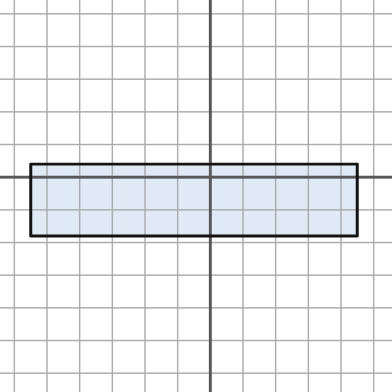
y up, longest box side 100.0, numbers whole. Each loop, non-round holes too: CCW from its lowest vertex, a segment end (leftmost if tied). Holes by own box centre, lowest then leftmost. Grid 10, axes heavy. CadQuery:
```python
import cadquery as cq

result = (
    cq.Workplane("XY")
    .moveTo(-55.0, -18.0)
    .lineTo(45.0, -18.0)
    .lineTo(45.0, 4.0)
    .lineTo(-55.0, 4.0)
    .close()
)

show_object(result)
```